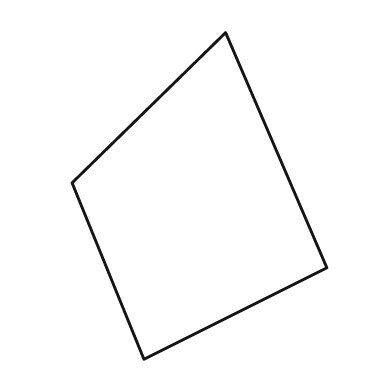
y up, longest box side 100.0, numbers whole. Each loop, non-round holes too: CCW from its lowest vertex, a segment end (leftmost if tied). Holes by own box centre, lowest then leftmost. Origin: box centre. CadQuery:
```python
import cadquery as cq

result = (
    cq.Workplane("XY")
    .moveTo(-17.0, -50.0)
    .lineTo(39.0, -22.0)
    .lineTo(8.0, 50.0)
    .lineTo(-39.0, 4.0)
    .close()
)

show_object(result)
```